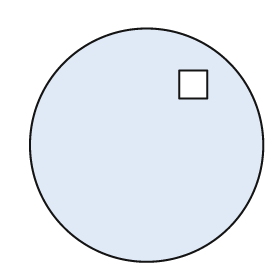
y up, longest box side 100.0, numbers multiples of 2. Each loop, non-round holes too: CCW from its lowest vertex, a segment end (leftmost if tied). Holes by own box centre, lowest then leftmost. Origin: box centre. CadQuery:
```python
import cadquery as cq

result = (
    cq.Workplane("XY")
    .moveTo(0.0, 0.0)
    .circle(50.0)
    .moveTo(14.0, 20.0)
    .lineTo(26.0, 20.0)
    .lineTo(26.0, 32.0)
    .lineTo(14.0, 32.0)
    .close()
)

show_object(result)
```